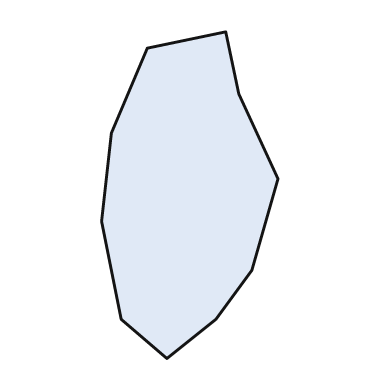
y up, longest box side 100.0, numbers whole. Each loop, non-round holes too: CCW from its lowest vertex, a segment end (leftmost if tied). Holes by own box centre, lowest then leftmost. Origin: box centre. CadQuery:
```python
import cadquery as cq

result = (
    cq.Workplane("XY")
    .moveTo(-7.0, -50.0)
    .lineTo(8.0, -38.0)
    .lineTo(19.0, -23.0)
    .lineTo(27.0, 5.0)
    .lineTo(15.0, 31.0)
    .lineTo(11.0, 50.0)
    .lineTo(-13.0, 45.0)
    .lineTo(-24.0, 19.0)
    .lineTo(-27.0, -8.0)
    .lineTo(-21.0, -38.0)
    .close()
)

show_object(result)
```